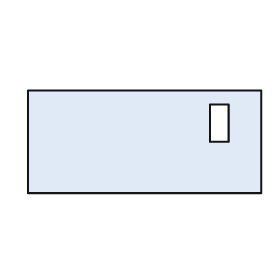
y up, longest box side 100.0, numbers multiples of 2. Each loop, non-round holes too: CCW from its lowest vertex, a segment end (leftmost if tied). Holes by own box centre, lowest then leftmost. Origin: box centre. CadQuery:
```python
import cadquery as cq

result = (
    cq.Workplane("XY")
    .moveTo(-50.0, -22.0)
    .lineTo(50.0, -22.0)
    .lineTo(50.0, 22.0)
    .lineTo(-50.0, 22.0)
    .close()
    .moveTo(28.0, 0.0)
    .lineTo(36.0, 0.0)
    .lineTo(36.0, 16.0)
    .lineTo(28.0, 16.0)
    .close()
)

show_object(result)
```